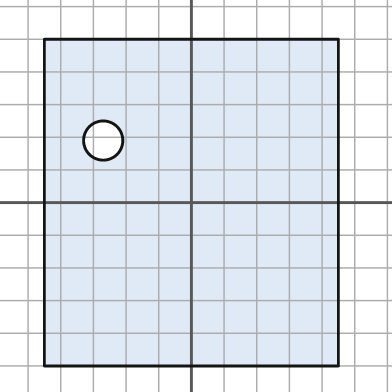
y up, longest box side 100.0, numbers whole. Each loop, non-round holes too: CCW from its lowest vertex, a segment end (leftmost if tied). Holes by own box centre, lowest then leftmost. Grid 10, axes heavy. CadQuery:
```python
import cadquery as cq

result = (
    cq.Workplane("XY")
    .moveTo(-45.0, -50.0)
    .lineTo(45.0, -50.0)
    .lineTo(45.0, 50.0)
    .lineTo(-45.0, 50.0)
    .close()
    .moveTo(-27.0, 19.0)
    .circle(6.0)
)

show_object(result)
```